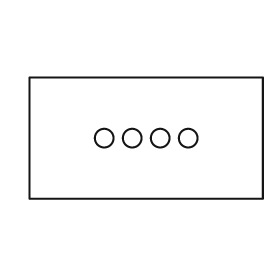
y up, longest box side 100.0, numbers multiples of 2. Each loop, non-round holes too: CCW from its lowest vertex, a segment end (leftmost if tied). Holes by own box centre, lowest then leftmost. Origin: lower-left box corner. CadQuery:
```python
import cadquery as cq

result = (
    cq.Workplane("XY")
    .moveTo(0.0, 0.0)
    .lineTo(100.0, 0.0)
    .lineTo(100.0, 52.0)
    .lineTo(0.0, 52.0)
    .close()
    .moveTo(32.0, 26.0)
    .circle(4.0)
    .moveTo(44.0, 26.0)
    .circle(4.0)
    .moveTo(56.0, 26.0)
    .circle(4.0)
    .moveTo(68.0, 26.0)
    .circle(4.0)
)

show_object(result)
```